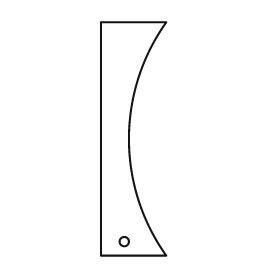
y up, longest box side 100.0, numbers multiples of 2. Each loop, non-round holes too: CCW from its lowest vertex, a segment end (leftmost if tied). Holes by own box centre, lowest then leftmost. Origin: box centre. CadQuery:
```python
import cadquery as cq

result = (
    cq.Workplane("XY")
    .moveTo(-14.0, -50.0)
    .lineTo(14.0, -50.0)
    .threePointArc((-2.0, 0.0), (14.0, 50.0))
    .lineTo(-14.0, 50.0)
    .close()
    .moveTo(-4.0, -44.0)
    .circle(2.0)
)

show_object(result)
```